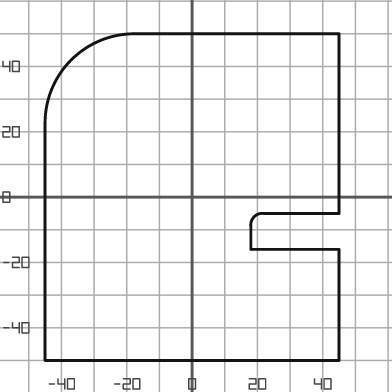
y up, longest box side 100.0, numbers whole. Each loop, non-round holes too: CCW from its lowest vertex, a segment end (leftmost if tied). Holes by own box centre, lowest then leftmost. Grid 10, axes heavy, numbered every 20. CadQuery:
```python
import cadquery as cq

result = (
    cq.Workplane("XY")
    .moveTo(-45.0, -50.0)
    .lineTo(45.0, -50.0)
    .lineTo(45.0, -16.0)
    .lineTo(18.0, -16.0)
    .lineTo(18.0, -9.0)
    .threePointArc((19.0, -6.0), (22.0, -5.0))
    .lineTo(45.0, -5.0)
    .lineTo(45.0, 50.0)
    .lineTo(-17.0, 50.0)
    .threePointArc((-37.0, 42.0), (-45.0, 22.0))
    .close()
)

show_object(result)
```